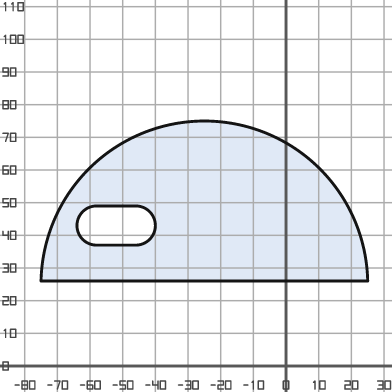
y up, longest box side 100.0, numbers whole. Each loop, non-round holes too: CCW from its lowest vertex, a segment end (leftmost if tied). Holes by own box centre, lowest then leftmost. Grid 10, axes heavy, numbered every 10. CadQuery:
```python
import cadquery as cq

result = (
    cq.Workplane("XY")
    .moveTo(-75.0, 26.0)
    .lineTo(25.0, 26.0)
    .threePointArc((-25.0, 75.0), (-75.0, 26.0))
    .close()
    .moveTo(-58.0, 37.0)
    .lineTo(-46.0, 37.0)
    .threePointArc((-40.0, 43.0), (-46.0, 49.0))
    .lineTo(-58.0, 49.0)
    .threePointArc((-64.0, 43.0), (-58.0, 37.0))
    .close()
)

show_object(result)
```